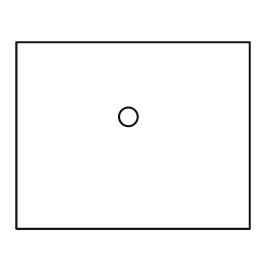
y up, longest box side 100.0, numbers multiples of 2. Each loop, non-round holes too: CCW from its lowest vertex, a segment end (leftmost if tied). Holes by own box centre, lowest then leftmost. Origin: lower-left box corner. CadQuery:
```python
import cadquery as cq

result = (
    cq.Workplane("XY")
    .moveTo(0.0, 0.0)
    .lineTo(100.0, 0.0)
    .lineTo(100.0, 80.0)
    .lineTo(0.0, 80.0)
    .close()
    .moveTo(48.0, 48.0)
    .circle(4.0)
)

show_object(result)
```